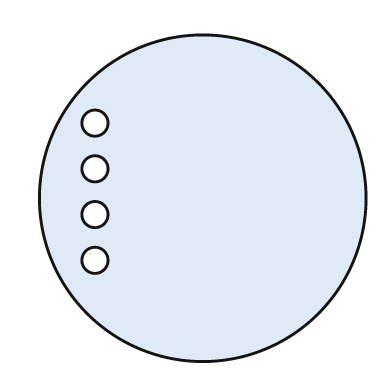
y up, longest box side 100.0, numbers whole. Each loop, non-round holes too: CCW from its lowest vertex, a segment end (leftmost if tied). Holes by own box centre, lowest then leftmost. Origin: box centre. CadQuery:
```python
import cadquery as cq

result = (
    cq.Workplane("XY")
    .moveTo(0.0, 0.0)
    .circle(50.0)
    .moveTo(-33.0, -19.0)
    .circle(4.0)
    .moveTo(-33.0, -5.0)
    .circle(4.0)
    .moveTo(-33.0, 9.0)
    .circle(4.0)
    .moveTo(-33.0, 23.0)
    .circle(4.0)
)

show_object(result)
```